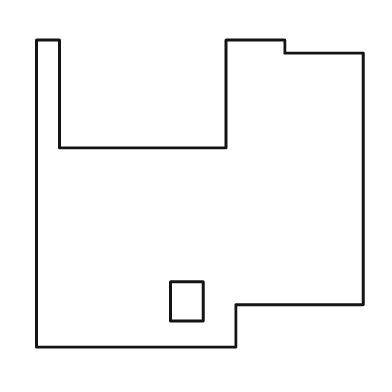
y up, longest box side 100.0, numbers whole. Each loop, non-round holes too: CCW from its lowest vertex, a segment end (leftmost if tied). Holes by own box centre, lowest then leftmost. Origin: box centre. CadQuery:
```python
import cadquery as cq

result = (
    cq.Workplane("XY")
    .moveTo(-50.0, -47.0)
    .lineTo(11.0, -47.0)
    .lineTo(11.0, -34.0)
    .lineTo(50.0, -34.0)
    .lineTo(50.0, 43.0)
    .lineTo(26.0, 43.0)
    .lineTo(26.0, 47.0)
    .lineTo(8.0, 47.0)
    .lineTo(8.0, 14.0)
    .lineTo(-43.0, 14.0)
    .lineTo(-43.0, 47.0)
    .lineTo(-50.0, 47.0)
    .close()
    .moveTo(-9.0, -39.0)
    .lineTo(1.0, -39.0)
    .lineTo(1.0, -27.0)
    .lineTo(-9.0, -27.0)
    .close()
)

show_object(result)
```